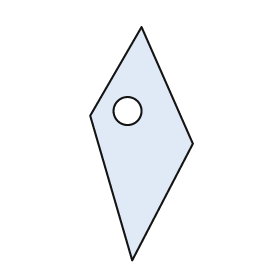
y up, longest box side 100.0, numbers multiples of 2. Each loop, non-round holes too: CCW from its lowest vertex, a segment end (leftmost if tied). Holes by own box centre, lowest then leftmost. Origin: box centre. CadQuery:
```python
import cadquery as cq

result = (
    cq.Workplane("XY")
    .moveTo(-4.0, -50.0)
    .lineTo(22.0, 0.0)
    .lineTo(0.0, 50.0)
    .lineTo(-22.0, 12.0)
    .close()
    .moveTo(-6.0, 14.0)
    .circle(6.0)
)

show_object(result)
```